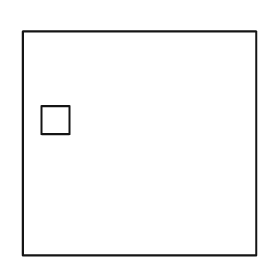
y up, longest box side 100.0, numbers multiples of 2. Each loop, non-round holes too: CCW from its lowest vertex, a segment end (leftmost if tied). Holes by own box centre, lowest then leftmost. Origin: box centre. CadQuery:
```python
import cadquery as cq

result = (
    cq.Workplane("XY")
    .moveTo(-50.0, -48.0)
    .lineTo(50.0, -48.0)
    .lineTo(50.0, 48.0)
    .lineTo(-50.0, 48.0)
    .close()
    .moveTo(-42.0, 4.0)
    .lineTo(-30.0, 4.0)
    .lineTo(-30.0, 16.0)
    .lineTo(-42.0, 16.0)
    .close()
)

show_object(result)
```